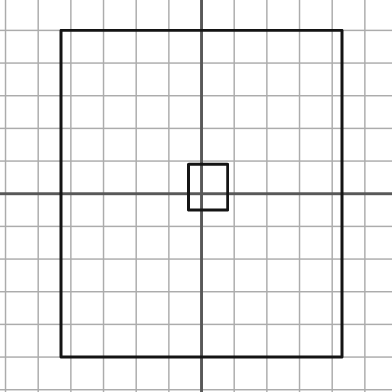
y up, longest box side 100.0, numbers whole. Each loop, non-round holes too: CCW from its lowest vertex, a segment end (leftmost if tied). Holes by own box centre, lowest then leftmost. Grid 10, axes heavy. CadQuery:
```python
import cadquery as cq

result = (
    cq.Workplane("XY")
    .moveTo(-43.0, -50.0)
    .lineTo(43.0, -50.0)
    .lineTo(43.0, 50.0)
    .lineTo(-43.0, 50.0)
    .close()
    .moveTo(-4.0, -5.0)
    .lineTo(8.0, -5.0)
    .lineTo(8.0, 9.0)
    .lineTo(-4.0, 9.0)
    .close()
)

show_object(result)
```